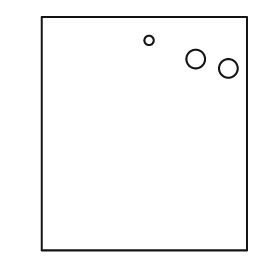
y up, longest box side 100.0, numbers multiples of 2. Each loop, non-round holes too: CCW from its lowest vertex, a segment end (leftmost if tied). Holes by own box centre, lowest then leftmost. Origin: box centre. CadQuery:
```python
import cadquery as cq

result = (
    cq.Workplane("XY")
    .moveTo(-44.0, -50.0)
    .lineTo(44.0, -50.0)
    .lineTo(44.0, 50.0)
    .lineTo(-44.0, 50.0)
    .close()
    .moveTo(36.0, 28.0)
    .circle(4.0)
    .moveTo(22.0, 32.0)
    .circle(4.0)
    .moveTo(2.0, 40.0)
    .circle(2.0)
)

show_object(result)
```